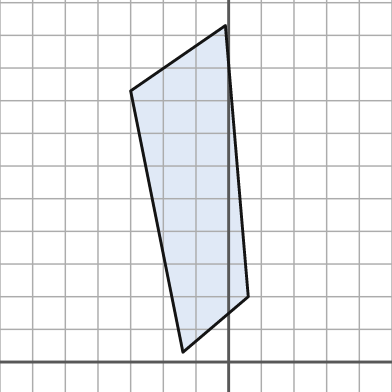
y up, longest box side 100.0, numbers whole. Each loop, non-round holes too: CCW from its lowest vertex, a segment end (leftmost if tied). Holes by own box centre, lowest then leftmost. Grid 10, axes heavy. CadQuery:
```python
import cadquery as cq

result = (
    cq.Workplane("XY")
    .moveTo(-14.0, 3.0)
    .lineTo(6.0, 20.0)
    .lineTo(-1.0, 103.0)
    .lineTo(-30.0, 83.0)
    .close()
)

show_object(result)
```